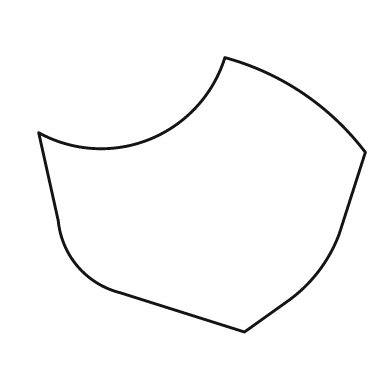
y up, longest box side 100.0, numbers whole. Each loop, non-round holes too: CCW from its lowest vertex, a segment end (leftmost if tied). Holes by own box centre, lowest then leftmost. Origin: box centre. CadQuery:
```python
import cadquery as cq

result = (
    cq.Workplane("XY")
    .moveTo(13.0, -42.0)
    .lineTo(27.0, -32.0)
    .threePointArc((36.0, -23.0), (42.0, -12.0))
    .lineTo(50.0, 13.0)
    .threePointArc((31.0, 31.0), (7.0, 42.0))
    .threePointArc((-16.0, 17.0), (-50.0, 19.0))
    .lineTo(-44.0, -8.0)
    .threePointArc((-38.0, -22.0), (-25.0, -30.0))
    .close()
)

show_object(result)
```